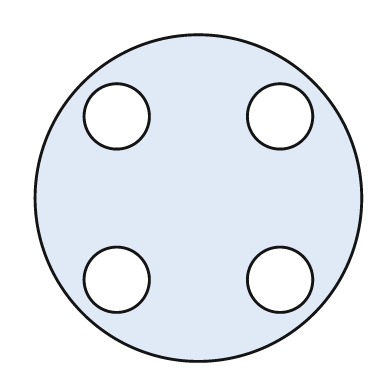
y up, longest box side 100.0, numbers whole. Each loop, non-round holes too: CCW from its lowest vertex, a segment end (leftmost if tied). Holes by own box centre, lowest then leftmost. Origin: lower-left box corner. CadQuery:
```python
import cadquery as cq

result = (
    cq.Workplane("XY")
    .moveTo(50.0, 50.0)
    .circle(50.0)
    .moveTo(25.0, 25.0)
    .circle(10.0)
    .moveTo(75.0, 25.0)
    .circle(10.0)
    .moveTo(25.0, 75.0)
    .circle(10.0)
    .moveTo(75.0, 75.0)
    .circle(10.0)
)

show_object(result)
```